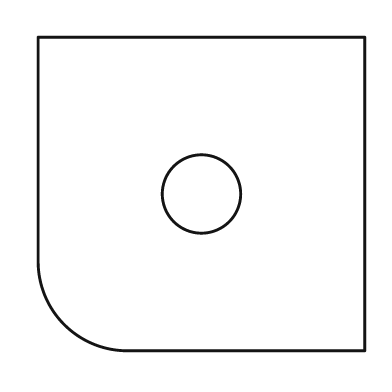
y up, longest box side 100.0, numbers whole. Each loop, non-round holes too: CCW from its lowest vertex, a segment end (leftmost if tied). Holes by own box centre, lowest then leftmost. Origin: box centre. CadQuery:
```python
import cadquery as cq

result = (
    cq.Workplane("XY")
    .moveTo(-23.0, -48.0)
    .lineTo(50.0, -48.0)
    .lineTo(50.0, 48.0)
    .lineTo(-50.0, 48.0)
    .lineTo(-50.0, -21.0)
    .threePointArc((-42.0, -40.0), (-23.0, -48.0))
    .close()
    .moveTo(0.0, 0.0)
    .circle(12.0)
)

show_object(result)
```